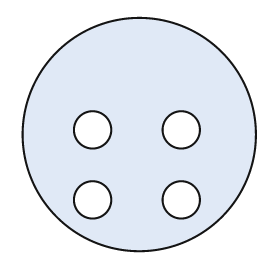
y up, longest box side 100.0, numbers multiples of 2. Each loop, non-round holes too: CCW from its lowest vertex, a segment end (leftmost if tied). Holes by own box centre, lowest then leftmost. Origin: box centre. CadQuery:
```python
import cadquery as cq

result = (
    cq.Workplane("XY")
    .moveTo(0.0, 0.0)
    .circle(50.0)
    .moveTo(-20.0, -28.0)
    .circle(8.0)
    .moveTo(18.0, -28.0)
    .circle(8.0)
    .moveTo(-20.0, 2.0)
    .circle(8.0)
    .moveTo(18.0, 2.0)
    .circle(8.0)
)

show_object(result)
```